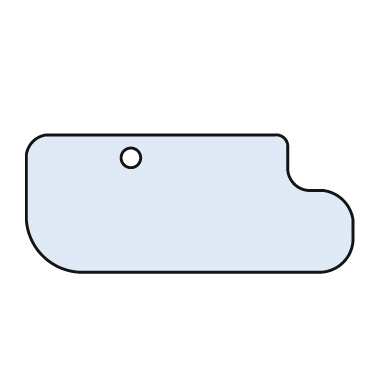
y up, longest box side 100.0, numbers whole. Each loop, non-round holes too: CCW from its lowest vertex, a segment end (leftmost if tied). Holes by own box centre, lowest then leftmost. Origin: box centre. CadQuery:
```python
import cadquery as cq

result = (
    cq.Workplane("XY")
    .moveTo(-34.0, -21.0)
    .lineTo(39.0, -21.0)
    .threePointArc((47.0, -18.0), (50.0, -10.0))
    .lineTo(50.0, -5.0)
    .threePointArc((47.0, 1.0), (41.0, 4.0))
    .lineTo(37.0, 4.0)
    .threePointArc((32.0, 6.0), (30.0, 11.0))
    .lineTo(30.0, 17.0)
    .threePointArc((29.0, 20.0), (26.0, 21.0))
    .lineTo(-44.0, 21.0)
    .threePointArc((-48.0, 19.0), (-50.0, 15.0))
    .lineTo(-50.0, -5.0)
    .threePointArc((-45.0, -16.0), (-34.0, -21.0))
    .close()
    .moveTo(-18.0, 14.0)
    .circle(3.0)
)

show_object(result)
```